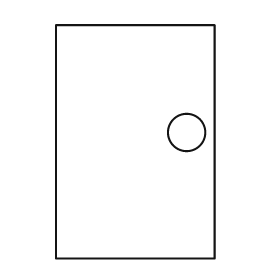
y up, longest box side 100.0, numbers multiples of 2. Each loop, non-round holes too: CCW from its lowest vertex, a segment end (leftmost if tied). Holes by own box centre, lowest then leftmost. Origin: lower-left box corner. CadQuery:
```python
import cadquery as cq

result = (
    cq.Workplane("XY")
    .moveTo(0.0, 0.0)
    .lineTo(68.0, 0.0)
    .lineTo(68.0, 100.0)
    .lineTo(0.0, 100.0)
    .close()
    .moveTo(56.0, 54.0)
    .circle(8.0)
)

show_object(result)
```